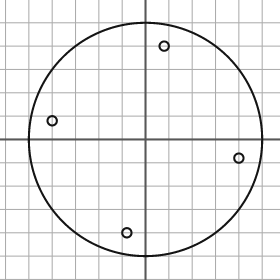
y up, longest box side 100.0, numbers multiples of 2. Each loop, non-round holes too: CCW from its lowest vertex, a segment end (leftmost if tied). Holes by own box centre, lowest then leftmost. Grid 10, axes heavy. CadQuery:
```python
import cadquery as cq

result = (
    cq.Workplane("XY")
    .moveTo(0.0, 0.0)
    .circle(50.0)
    .moveTo(-8.0, -40.0)
    .circle(2.0)
    .moveTo(40.0, -8.0)
    .circle(2.0)
    .moveTo(-40.0, 8.0)
    .circle(2.0)
    .moveTo(8.0, 40.0)
    .circle(2.0)
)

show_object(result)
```